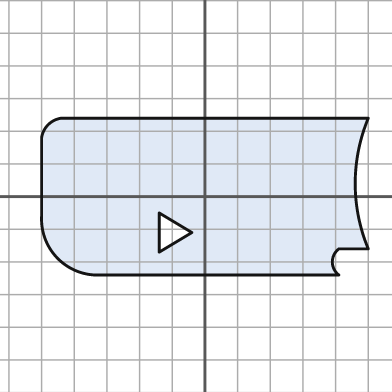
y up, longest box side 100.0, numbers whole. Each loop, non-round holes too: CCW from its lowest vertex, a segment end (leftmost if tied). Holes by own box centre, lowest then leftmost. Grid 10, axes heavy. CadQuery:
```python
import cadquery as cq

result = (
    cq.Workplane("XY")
    .moveTo(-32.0, -24.0)
    .lineTo(41.0, -24.0)
    .threePointArc((39.0, -20.0), (41.0, -16.0))
    .lineTo(50.0, -16.0)
    .threePointArc((46.0, 4.0), (50.0, 24.0))
    .lineTo(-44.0, 24.0)
    .threePointArc((-48.0, 22.0), (-50.0, 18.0))
    .lineTo(-50.0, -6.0)
    .threePointArc((-45.0, -19.0), (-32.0, -24.0))
    .close()
    .moveTo(-14.0, -17.0)
    .lineTo(-4.0, -11.0)
    .lineTo(-14.0, -5.0)
    .close()
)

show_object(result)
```